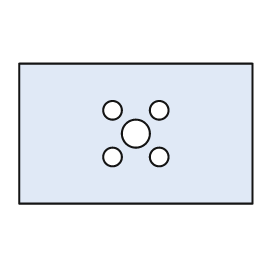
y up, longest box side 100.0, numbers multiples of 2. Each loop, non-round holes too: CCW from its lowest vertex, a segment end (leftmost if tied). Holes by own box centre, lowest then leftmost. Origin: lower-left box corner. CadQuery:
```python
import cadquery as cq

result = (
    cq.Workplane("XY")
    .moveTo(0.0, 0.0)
    .lineTo(100.0, 0.0)
    .lineTo(100.0, 60.0)
    .lineTo(0.0, 60.0)
    .close()
    .moveTo(40.0, 20.0)
    .circle(4.0)
    .moveTo(60.0, 20.0)
    .circle(4.0)
    .moveTo(50.0, 30.0)
    .circle(6.0)
    .moveTo(40.0, 40.0)
    .circle(4.0)
    .moveTo(60.0, 40.0)
    .circle(4.0)
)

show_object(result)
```